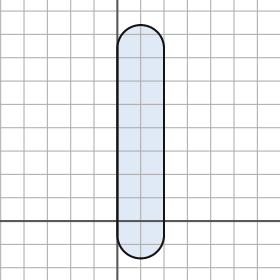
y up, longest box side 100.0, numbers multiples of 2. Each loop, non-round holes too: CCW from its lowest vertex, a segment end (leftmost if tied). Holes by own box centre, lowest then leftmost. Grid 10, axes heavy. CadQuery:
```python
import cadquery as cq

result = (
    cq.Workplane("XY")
    .moveTo(0.0, -6.0)
    .threePointArc((10.0, -16.0), (20.0, -6.0))
    .lineTo(20.0, 74.0)
    .threePointArc((10.0, 84.0), (0.0, 74.0))
    .close()
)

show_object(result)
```